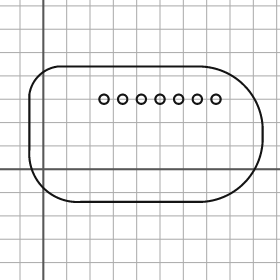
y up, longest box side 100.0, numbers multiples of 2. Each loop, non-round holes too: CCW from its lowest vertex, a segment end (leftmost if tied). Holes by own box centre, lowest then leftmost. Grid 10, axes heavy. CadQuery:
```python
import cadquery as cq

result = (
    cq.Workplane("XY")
    .moveTo(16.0, -14.0)
    .lineTo(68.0, -14.0)
    .threePointArc((86.0, -6.0), (94.0, 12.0))
    .lineTo(94.0, 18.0)
    .threePointArc((86.0, 36.0), (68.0, 44.0))
    .lineTo(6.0, 44.0)
    .threePointArc((-2.0, 40.0), (-6.0, 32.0))
    .lineTo(-6.0, 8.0)
    .threePointArc((0.0, -8.0), (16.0, -14.0))
    .close()
    .moveTo(26.0, 30.0)
    .circle(2.0)
    .moveTo(34.0, 30.0)
    .circle(2.0)
    .moveTo(42.0, 30.0)
    .circle(2.0)
    .moveTo(50.0, 30.0)
    .circle(2.0)
    .moveTo(58.0, 30.0)
    .circle(2.0)
    .moveTo(66.0, 30.0)
    .circle(2.0)
    .moveTo(74.0, 30.0)
    .circle(2.0)
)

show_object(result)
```